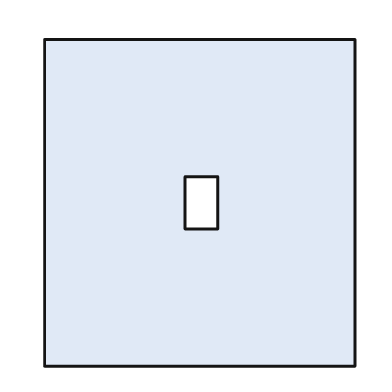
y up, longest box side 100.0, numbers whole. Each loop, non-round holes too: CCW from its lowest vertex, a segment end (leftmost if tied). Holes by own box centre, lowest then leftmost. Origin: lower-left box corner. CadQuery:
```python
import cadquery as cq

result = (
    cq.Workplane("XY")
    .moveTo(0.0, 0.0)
    .lineTo(95.0, 0.0)
    .lineTo(95.0, 100.0)
    .lineTo(0.0, 100.0)
    .close()
    .moveTo(43.0, 42.0)
    .lineTo(53.0, 42.0)
    .lineTo(53.0, 58.0)
    .lineTo(43.0, 58.0)
    .close()
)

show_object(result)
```